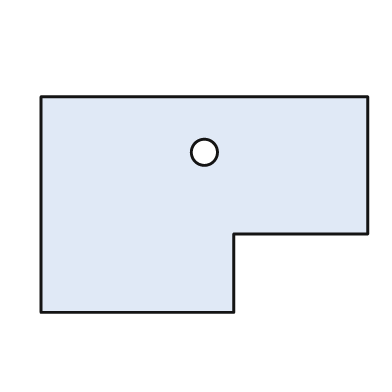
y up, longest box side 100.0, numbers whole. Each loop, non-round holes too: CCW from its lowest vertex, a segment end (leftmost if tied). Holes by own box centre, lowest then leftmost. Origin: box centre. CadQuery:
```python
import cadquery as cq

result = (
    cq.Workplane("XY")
    .moveTo(-50.0, -33.0)
    .lineTo(9.0, -33.0)
    .lineTo(9.0, -9.0)
    .lineTo(50.0, -9.0)
    .lineTo(50.0, 33.0)
    .lineTo(-50.0, 33.0)
    .close()
    .moveTo(0.0, 16.0)
    .circle(4.0)
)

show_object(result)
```